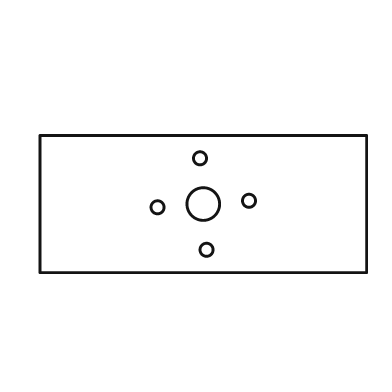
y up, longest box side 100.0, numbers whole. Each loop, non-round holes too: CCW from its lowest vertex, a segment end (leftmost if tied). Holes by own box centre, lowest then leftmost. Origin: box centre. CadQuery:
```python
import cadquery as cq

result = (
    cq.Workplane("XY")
    .moveTo(-50.0, -21.0)
    .lineTo(50.0, -21.0)
    .lineTo(50.0, 21.0)
    .lineTo(-50.0, 21.0)
    .close()
    .moveTo(1.0, -14.0)
    .circle(2.0)
    .moveTo(-14.0, -1.0)
    .circle(2.0)
    .moveTo(0.0, 0.0)
    .circle(5.0)
    .moveTo(14.0, 1.0)
    .circle(2.0)
    .moveTo(-1.0, 14.0)
    .circle(2.0)
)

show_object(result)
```